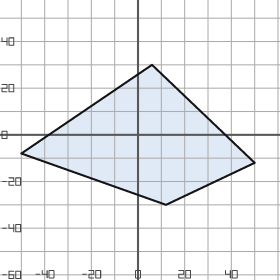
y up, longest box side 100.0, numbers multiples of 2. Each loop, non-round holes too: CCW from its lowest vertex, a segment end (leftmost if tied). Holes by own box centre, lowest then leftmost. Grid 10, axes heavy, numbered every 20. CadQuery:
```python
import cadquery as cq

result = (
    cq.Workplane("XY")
    .moveTo(12.0, -30.0)
    .lineTo(50.0, -12.0)
    .lineTo(6.0, 30.0)
    .lineTo(-50.0, -8.0)
    .close()
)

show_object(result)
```